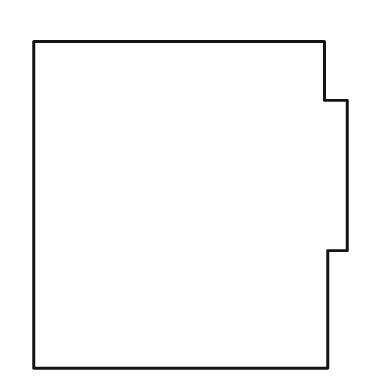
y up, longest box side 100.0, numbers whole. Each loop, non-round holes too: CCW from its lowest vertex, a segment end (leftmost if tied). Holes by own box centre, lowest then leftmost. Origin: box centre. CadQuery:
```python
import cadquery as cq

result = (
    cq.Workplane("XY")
    .moveTo(-48.0, -50.0)
    .lineTo(42.0, -50.0)
    .lineTo(42.0, -14.0)
    .lineTo(48.0, -14.0)
    .lineTo(48.0, 32.0)
    .lineTo(41.0, 32.0)
    .lineTo(41.0, 50.0)
    .lineTo(-48.0, 50.0)
    .close()
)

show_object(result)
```